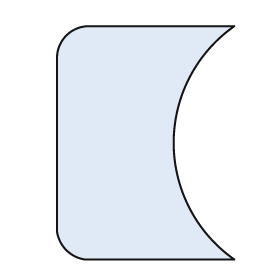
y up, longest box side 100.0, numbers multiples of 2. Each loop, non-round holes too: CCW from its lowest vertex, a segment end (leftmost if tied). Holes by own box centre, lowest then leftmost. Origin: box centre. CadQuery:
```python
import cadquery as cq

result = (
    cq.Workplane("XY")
    .moveTo(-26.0, -50.0)
    .lineTo(38.0, -50.0)
    .threePointArc((12.0, 0.0), (38.0, 50.0))
    .lineTo(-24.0, 50.0)
    .threePointArc((-34.0, 46.0), (-38.0, 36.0))
    .lineTo(-38.0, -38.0)
    .threePointArc((-34.0, -46.0), (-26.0, -50.0))
    .close()
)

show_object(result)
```